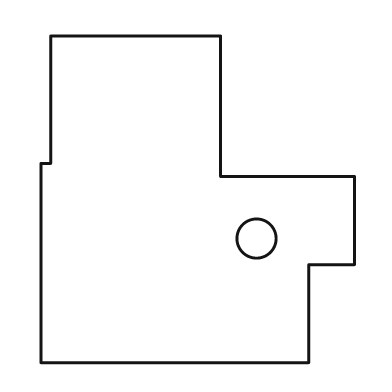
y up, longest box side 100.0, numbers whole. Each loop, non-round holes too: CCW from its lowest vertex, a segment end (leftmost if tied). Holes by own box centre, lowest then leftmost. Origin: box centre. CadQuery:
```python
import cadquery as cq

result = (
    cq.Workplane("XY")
    .moveTo(-48.0, -50.0)
    .lineTo(34.0, -50.0)
    .lineTo(34.0, -20.0)
    .lineTo(48.0, -20.0)
    .lineTo(48.0, 7.0)
    .lineTo(7.0, 7.0)
    .lineTo(7.0, 50.0)
    .lineTo(-45.0, 50.0)
    .lineTo(-45.0, 11.0)
    .lineTo(-48.0, 11.0)
    .close()
    .moveTo(18.0, -12.0)
    .circle(6.0)
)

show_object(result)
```